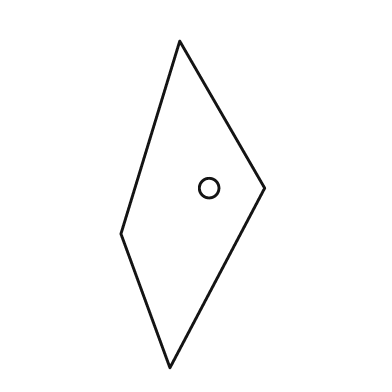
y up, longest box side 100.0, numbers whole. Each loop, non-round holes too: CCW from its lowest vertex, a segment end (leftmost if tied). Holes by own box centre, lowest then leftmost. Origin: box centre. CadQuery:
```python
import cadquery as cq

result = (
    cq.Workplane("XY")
    .moveTo(-7.0, -50.0)
    .lineTo(22.0, 5.0)
    .lineTo(-4.0, 50.0)
    .lineTo(-22.0, -9.0)
    .close()
    .moveTo(5.0, 5.0)
    .circle(3.0)
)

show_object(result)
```